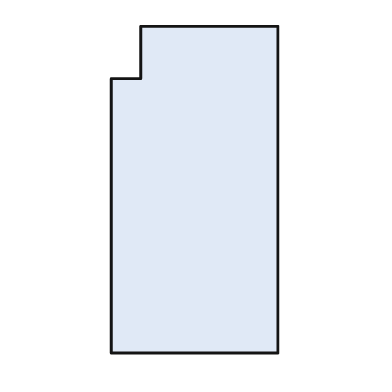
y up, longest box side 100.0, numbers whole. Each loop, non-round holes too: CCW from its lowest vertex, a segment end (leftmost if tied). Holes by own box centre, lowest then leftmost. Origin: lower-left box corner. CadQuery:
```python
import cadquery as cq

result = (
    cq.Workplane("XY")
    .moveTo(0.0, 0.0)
    .lineTo(51.0, 0.0)
    .lineTo(51.0, 100.0)
    .lineTo(9.0, 100.0)
    .lineTo(9.0, 84.0)
    .lineTo(0.0, 84.0)
    .close()
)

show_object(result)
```